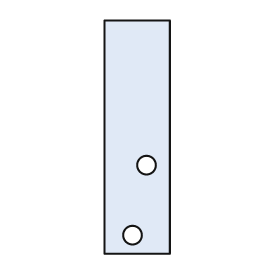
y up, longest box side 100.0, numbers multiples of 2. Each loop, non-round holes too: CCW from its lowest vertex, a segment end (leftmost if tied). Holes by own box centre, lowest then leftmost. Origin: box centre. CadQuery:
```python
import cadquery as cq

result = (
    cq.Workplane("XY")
    .moveTo(-14.0, -50.0)
    .lineTo(14.0, -50.0)
    .lineTo(14.0, 50.0)
    .lineTo(-14.0, 50.0)
    .close()
    .moveTo(-2.0, -42.0)
    .circle(4.0)
    .moveTo(4.0, -12.0)
    .circle(4.0)
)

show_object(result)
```